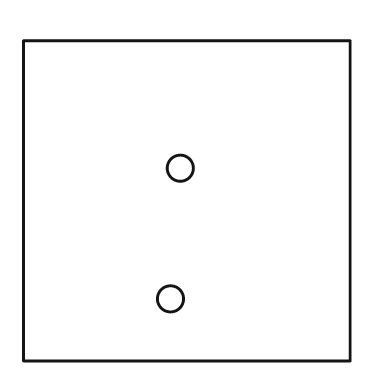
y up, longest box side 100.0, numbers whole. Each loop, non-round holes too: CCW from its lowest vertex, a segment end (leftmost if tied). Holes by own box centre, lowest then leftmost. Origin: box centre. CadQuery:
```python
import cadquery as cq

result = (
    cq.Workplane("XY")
    .moveTo(-50.0, -49.0)
    .lineTo(50.0, -49.0)
    .lineTo(50.0, 49.0)
    .lineTo(-50.0, 49.0)
    .close()
    .moveTo(-5.0, -30.0)
    .circle(4.0)
    .moveTo(-2.0, 10.0)
    .circle(4.0)
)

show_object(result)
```